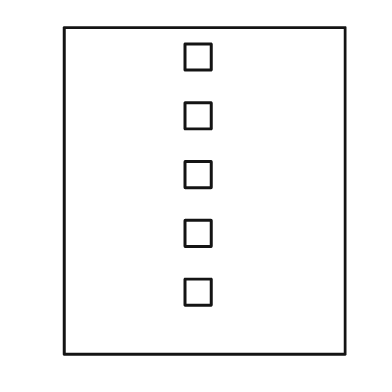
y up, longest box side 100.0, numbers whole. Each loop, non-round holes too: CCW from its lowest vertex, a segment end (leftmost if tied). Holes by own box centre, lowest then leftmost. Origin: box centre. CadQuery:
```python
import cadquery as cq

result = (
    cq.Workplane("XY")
    .moveTo(-43.0, -50.0)
    .lineTo(43.0, -50.0)
    .lineTo(43.0, 50.0)
    .lineTo(-43.0, 50.0)
    .close()
    .moveTo(-6.0, -35.0)
    .lineTo(2.0, -35.0)
    .lineTo(2.0, -27.0)
    .lineTo(-6.0, -27.0)
    .close()
    .moveTo(-6.0, -17.0)
    .lineTo(2.0, -17.0)
    .lineTo(2.0, -9.0)
    .lineTo(-6.0, -9.0)
    .close()
    .moveTo(-6.0, 1.0)
    .lineTo(2.0, 1.0)
    .lineTo(2.0, 9.0)
    .lineTo(-6.0, 9.0)
    .close()
    .moveTo(-6.0, 19.0)
    .lineTo(2.0, 19.0)
    .lineTo(2.0, 27.0)
    .lineTo(-6.0, 27.0)
    .close()
    .moveTo(-6.0, 37.0)
    .lineTo(2.0, 37.0)
    .lineTo(2.0, 45.0)
    .lineTo(-6.0, 45.0)
    .close()
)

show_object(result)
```